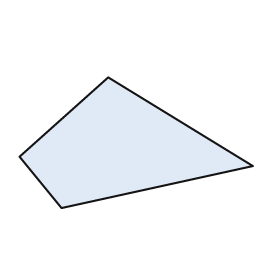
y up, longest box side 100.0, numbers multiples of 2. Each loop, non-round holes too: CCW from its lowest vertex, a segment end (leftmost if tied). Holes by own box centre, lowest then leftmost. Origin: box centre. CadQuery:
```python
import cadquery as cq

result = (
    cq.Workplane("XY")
    .moveTo(-32.0, -28.0)
    .lineTo(50.0, -10.0)
    .lineTo(-12.0, 28.0)
    .lineTo(-50.0, -6.0)
    .close()
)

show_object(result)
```